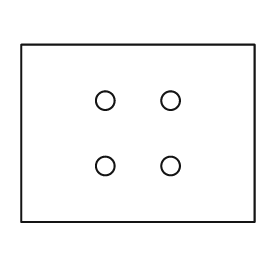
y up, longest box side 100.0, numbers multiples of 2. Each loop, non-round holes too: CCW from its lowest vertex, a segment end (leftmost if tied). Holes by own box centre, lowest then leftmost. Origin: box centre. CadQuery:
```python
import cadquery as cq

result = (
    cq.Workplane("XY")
    .moveTo(-50.0, -38.0)
    .lineTo(50.0, -38.0)
    .lineTo(50.0, 38.0)
    .lineTo(-50.0, 38.0)
    .close()
    .moveTo(-14.0, -14.0)
    .circle(4.0)
    .moveTo(14.0, -14.0)
    .circle(4.0)
    .moveTo(-14.0, 14.0)
    .circle(4.0)
    .moveTo(14.0, 14.0)
    .circle(4.0)
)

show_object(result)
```